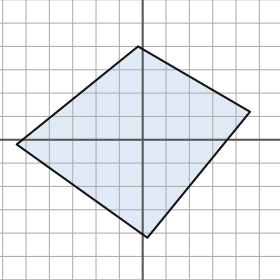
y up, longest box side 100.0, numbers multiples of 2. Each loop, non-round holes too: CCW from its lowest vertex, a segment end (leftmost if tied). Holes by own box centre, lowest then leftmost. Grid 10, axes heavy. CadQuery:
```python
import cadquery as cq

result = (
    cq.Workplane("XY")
    .moveTo(2.0, -42.0)
    .lineTo(46.0, 12.0)
    .lineTo(-2.0, 40.0)
    .lineTo(-54.0, -2.0)
    .close()
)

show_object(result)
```